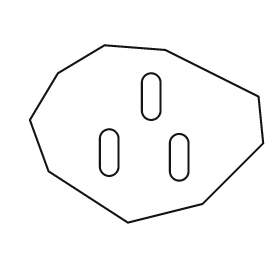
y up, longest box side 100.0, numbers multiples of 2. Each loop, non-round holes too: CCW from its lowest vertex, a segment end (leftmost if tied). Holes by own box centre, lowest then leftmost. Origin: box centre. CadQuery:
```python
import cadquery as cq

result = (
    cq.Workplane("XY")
    .moveTo(-8.0, -38.0)
    .lineTo(24.0, -30.0)
    .lineTo(50.0, -4.0)
    .lineTo(48.0, 16.0)
    .lineTo(8.0, 36.0)
    .lineTo(-18.0, 38.0)
    .lineTo(-38.0, 26.0)
    .lineTo(-50.0, 6.0)
    .lineTo(-42.0, -16.0)
    .close()
    .moveTo(10.0, -16.0)
    .threePointArc((14.0, -20.0), (18.0, -16.0))
    .lineTo(18.0, -4.0)
    .threePointArc((14.0, 0.0), (10.0, -4.0))
    .close()
    .moveTo(-20.0, -14.0)
    .threePointArc((-16.0, -18.0), (-12.0, -14.0))
    .lineTo(-12.0, -2.0)
    .threePointArc((-16.0, 2.0), (-20.0, -2.0))
    .close()
    .moveTo(-2.0, 10.0)
    .threePointArc((2.0, 6.0), (6.0, 10.0))
    .lineTo(6.0, 22.0)
    .threePointArc((2.0, 26.0), (-2.0, 22.0))
    .close()
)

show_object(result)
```